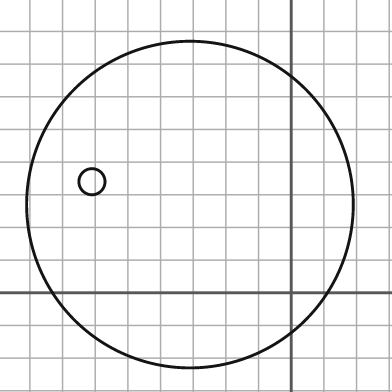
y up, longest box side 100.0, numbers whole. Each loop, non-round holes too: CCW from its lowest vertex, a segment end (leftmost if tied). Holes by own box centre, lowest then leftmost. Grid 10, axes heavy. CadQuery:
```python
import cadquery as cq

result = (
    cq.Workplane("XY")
    .moveTo(-31.0, 27.0)
    .circle(50.0)
    .moveTo(-61.0, 34.0)
    .circle(4.0)
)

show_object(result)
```